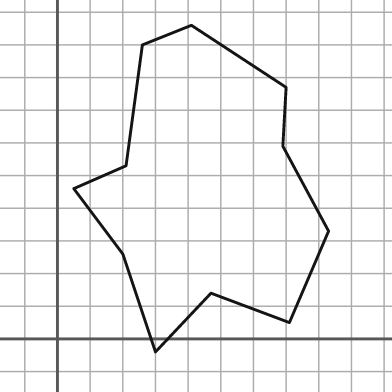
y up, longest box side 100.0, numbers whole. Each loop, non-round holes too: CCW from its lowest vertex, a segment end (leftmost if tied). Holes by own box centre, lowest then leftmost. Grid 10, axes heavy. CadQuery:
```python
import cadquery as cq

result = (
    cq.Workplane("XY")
    .moveTo(30.0, -4.0)
    .lineTo(47.0, 14.0)
    .lineTo(71.0, 5.0)
    .lineTo(83.0, 33.0)
    .lineTo(69.0, 59.0)
    .lineTo(70.0, 77.0)
    .lineTo(41.0, 96.0)
    .lineTo(26.0, 90.0)
    .lineTo(21.0, 53.0)
    .lineTo(5.0, 46.0)
    .lineTo(20.0, 26.0)
    .close()
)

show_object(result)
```